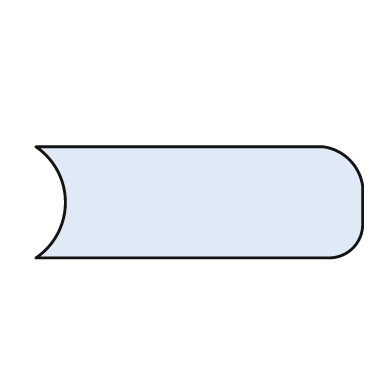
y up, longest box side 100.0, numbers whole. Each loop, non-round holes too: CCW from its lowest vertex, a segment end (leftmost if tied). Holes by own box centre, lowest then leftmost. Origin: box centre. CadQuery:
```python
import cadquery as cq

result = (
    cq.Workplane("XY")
    .moveTo(-50.0, -17.0)
    .lineTo(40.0, -17.0)
    .threePointArc((47.0, -14.0), (50.0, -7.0))
    .lineTo(50.0, 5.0)
    .threePointArc((46.0, 13.0), (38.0, 17.0))
    .lineTo(-50.0, 17.0)
    .threePointArc((-41.0, 0.0), (-50.0, -17.0))
    .close()
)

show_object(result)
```